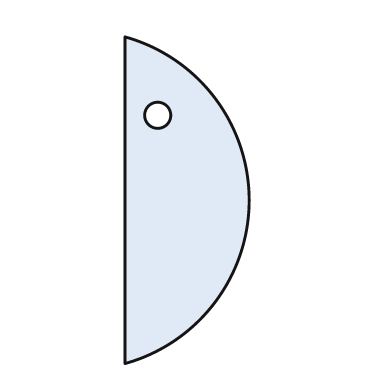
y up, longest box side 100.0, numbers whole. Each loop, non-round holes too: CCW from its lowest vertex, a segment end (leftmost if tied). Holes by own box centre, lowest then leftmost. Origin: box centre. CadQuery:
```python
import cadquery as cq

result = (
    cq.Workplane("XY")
    .moveTo(-19.0, -50.0)
    .threePointArc((19.0, 0.0), (-19.0, 50.0))
    .close()
    .moveTo(-9.0, 26.0)
    .circle(4.0)
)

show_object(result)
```